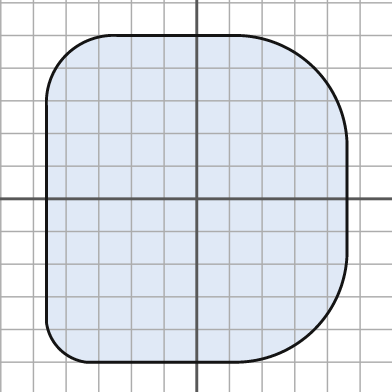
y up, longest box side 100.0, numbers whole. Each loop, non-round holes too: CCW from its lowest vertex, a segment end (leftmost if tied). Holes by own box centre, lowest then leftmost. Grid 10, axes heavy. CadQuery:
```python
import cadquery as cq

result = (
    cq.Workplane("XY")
    .moveTo(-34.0, -50.0)
    .lineTo(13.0, -50.0)
    .threePointArc((36.0, -40.0), (46.0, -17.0))
    .lineTo(46.0, 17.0)
    .threePointArc((36.0, 40.0), (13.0, 50.0))
    .lineTo(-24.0, 50.0)
    .threePointArc((-40.0, 44.0), (-46.0, 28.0))
    .lineTo(-46.0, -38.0)
    .threePointArc((-42.0, -46.0), (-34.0, -50.0))
    .close()
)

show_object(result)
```